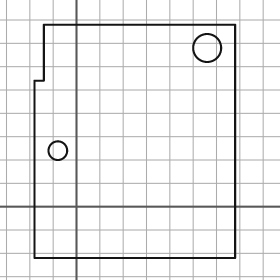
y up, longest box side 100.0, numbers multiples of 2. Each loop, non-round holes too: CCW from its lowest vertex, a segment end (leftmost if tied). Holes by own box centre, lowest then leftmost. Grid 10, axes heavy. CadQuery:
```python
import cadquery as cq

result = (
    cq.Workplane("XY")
    .moveTo(-18.0, -22.0)
    .lineTo(68.0, -22.0)
    .lineTo(68.0, 78.0)
    .lineTo(-14.0, 78.0)
    .lineTo(-14.0, 54.0)
    .lineTo(-18.0, 54.0)
    .close()
    .moveTo(-8.0, 24.0)
    .circle(4.0)
    .moveTo(56.0, 68.0)
    .circle(6.0)
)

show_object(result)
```